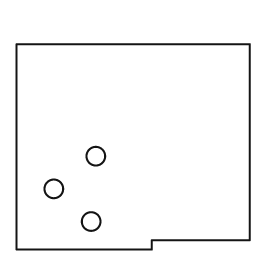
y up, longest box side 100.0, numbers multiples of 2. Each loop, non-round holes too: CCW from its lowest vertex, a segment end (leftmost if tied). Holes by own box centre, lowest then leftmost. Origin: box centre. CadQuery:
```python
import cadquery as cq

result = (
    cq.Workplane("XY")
    .moveTo(-50.0, -44.0)
    .lineTo(8.0, -44.0)
    .lineTo(8.0, -40.0)
    .lineTo(50.0, -40.0)
    .lineTo(50.0, 44.0)
    .lineTo(-50.0, 44.0)
    .close()
    .moveTo(-18.0, -32.0)
    .circle(4.0)
    .moveTo(-34.0, -18.0)
    .circle(4.0)
    .moveTo(-16.0, -4.0)
    .circle(4.0)
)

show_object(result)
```